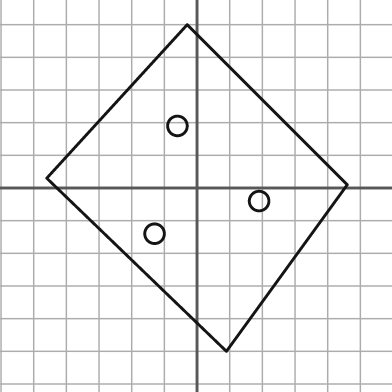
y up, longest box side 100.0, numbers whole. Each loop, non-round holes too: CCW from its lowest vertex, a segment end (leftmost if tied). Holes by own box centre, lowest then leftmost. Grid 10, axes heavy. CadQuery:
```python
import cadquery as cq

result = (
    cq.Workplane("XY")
    .moveTo(9.0, -50.0)
    .lineTo(46.0, 1.0)
    .lineTo(-3.0, 50.0)
    .lineTo(-46.0, 3.0)
    .close()
    .moveTo(-13.0, -14.0)
    .circle(3.0)
    .moveTo(19.0, -4.0)
    .circle(3.0)
    .moveTo(-6.0, 19.0)
    .circle(3.0)
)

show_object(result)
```